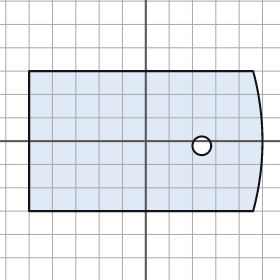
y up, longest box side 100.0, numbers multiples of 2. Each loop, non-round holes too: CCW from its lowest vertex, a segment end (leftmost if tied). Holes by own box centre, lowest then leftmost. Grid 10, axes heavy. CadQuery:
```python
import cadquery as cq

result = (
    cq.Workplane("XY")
    .moveTo(-50.0, -30.0)
    .lineTo(46.0, -30.0)
    .threePointArc((50.0, 0.0), (46.0, 30.0))
    .lineTo(-50.0, 30.0)
    .close()
    .moveTo(24.0, -2.0)
    .circle(4.0)
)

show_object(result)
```